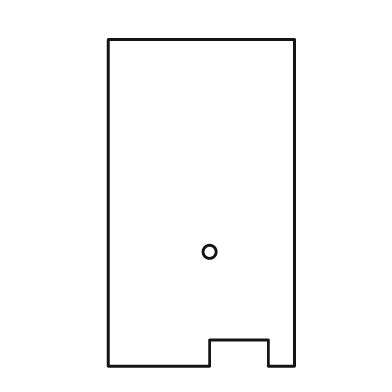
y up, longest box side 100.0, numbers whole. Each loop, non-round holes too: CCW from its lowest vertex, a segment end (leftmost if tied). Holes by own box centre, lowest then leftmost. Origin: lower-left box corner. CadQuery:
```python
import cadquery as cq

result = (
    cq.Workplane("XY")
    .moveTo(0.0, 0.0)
    .lineTo(31.0, 0.0)
    .lineTo(31.0, 8.0)
    .lineTo(49.0, 8.0)
    .lineTo(49.0, 0.0)
    .lineTo(57.0, 0.0)
    .lineTo(57.0, 100.0)
    .lineTo(0.0, 100.0)
    .close()
    .moveTo(31.0, 35.0)
    .circle(2.0)
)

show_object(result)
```